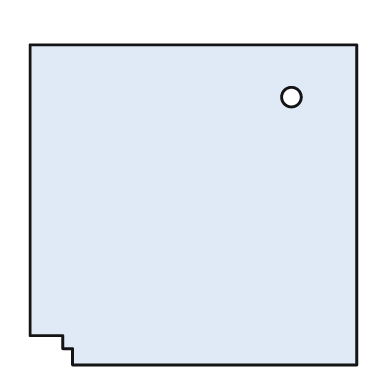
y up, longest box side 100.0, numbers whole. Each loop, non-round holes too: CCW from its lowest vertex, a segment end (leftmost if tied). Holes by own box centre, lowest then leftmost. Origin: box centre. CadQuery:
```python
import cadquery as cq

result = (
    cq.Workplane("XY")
    .moveTo(-37.0, -49.0)
    .lineTo(50.0, -49.0)
    .lineTo(50.0, 49.0)
    .lineTo(-50.0, 49.0)
    .lineTo(-50.0, -40.0)
    .lineTo(-40.0, -40.0)
    .lineTo(-40.0, -44.0)
    .lineTo(-37.0, -44.0)
    .close()
    .moveTo(30.0, 33.0)
    .circle(3.0)
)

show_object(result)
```